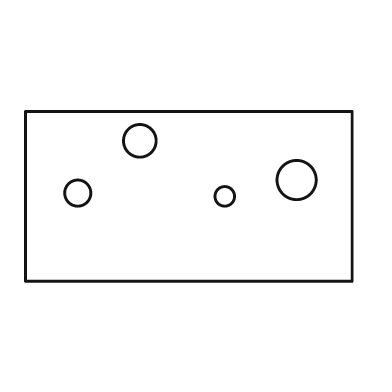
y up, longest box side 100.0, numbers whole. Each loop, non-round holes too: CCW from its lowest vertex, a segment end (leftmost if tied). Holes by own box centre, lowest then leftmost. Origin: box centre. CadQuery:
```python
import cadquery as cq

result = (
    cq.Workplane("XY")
    .moveTo(-50.0, -26.0)
    .lineTo(50.0, -26.0)
    .lineTo(50.0, 26.0)
    .lineTo(-50.0, 26.0)
    .close()
    .moveTo(11.0, 0.0)
    .circle(3.0)
    .moveTo(-34.0, 1.0)
    .circle(4.0)
    .moveTo(33.0, 5.0)
    .circle(6.0)
    .moveTo(-15.0, 17.0)
    .circle(5.0)
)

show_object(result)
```